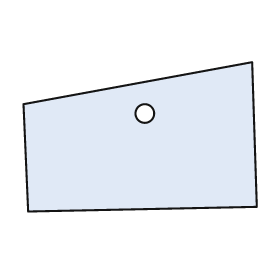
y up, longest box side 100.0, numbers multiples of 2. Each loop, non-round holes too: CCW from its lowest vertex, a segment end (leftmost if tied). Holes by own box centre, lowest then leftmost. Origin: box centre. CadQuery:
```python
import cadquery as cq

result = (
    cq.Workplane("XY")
    .moveTo(-48.0, -32.0)
    .lineTo(50.0, -30.0)
    .lineTo(48.0, 32.0)
    .lineTo(-50.0, 14.0)
    .close()
    .moveTo(2.0, 10.0)
    .circle(4.0)
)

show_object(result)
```